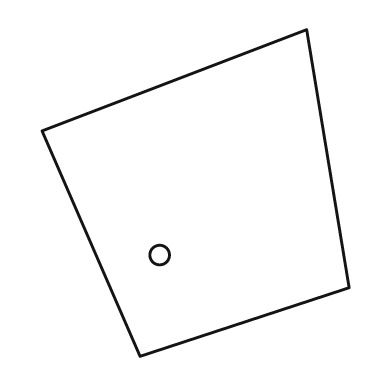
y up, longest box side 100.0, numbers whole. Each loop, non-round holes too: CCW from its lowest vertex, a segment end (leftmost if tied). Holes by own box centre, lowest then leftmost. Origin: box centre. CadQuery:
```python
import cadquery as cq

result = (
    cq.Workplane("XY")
    .moveTo(-17.0, -50.0)
    .lineTo(47.0, -29.0)
    .lineTo(34.0, 50.0)
    .lineTo(-47.0, 19.0)
    .close()
    .moveTo(-11.0, -19.0)
    .circle(3.0)
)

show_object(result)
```